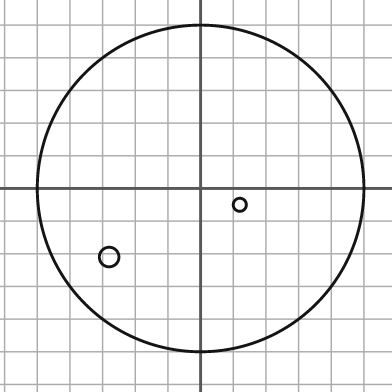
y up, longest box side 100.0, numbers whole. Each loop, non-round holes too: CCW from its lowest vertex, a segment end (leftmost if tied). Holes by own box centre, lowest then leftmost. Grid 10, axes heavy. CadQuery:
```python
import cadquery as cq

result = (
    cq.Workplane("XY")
    .moveTo(0.0, 0.0)
    .circle(50.0)
    .moveTo(-28.0, -21.0)
    .circle(3.0)
    .moveTo(12.0, -5.0)
    .circle(2.0)
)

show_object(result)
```